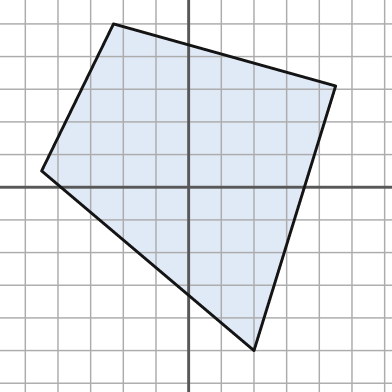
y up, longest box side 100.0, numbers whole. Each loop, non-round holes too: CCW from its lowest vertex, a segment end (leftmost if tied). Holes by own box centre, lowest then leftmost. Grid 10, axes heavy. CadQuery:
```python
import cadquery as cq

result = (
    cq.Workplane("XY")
    .moveTo(20.0, -50.0)
    .lineTo(45.0, 31.0)
    .lineTo(-23.0, 50.0)
    .lineTo(-45.0, 5.0)
    .close()
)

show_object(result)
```